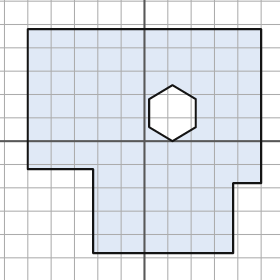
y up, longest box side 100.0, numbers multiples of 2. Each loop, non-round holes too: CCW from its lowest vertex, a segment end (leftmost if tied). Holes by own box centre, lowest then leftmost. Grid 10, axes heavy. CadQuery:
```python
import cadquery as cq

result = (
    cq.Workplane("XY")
    .moveTo(-22.0, -48.0)
    .lineTo(38.0, -48.0)
    .lineTo(38.0, -18.0)
    .lineTo(50.0, -18.0)
    .lineTo(50.0, 48.0)
    .lineTo(-50.0, 48.0)
    .lineTo(-50.0, -12.0)
    .lineTo(-22.0, -12.0)
    .close()
    .moveTo(12.0, 0.0)
    .lineTo(22.0, 6.0)
    .lineTo(22.0, 18.0)
    .lineTo(12.0, 24.0)
    .lineTo(2.0, 18.0)
    .lineTo(2.0, 6.0)
    .close()
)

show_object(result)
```